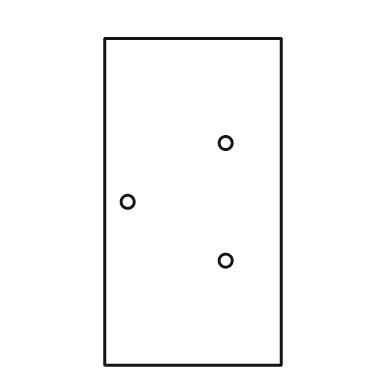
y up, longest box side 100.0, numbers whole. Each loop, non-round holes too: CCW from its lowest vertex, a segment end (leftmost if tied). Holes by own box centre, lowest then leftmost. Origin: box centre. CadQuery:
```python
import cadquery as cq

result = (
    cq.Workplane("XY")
    .moveTo(-27.0, -50.0)
    .lineTo(27.0, -50.0)
    .lineTo(27.0, 50.0)
    .lineTo(-27.0, 50.0)
    .close()
    .moveTo(10.0, -18.0)
    .circle(2.0)
    .moveTo(-20.0, 0.0)
    .circle(2.0)
    .moveTo(10.0, 18.0)
    .circle(2.0)
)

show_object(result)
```